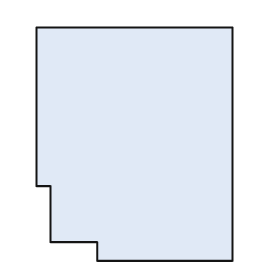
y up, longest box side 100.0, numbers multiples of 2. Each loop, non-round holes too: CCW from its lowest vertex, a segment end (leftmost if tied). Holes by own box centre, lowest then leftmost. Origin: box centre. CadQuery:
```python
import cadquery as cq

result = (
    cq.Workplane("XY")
    .moveTo(-16.0, -50.0)
    .lineTo(42.0, -50.0)
    .lineTo(42.0, 50.0)
    .lineTo(-42.0, 50.0)
    .lineTo(-42.0, -18.0)
    .lineTo(-36.0, -18.0)
    .lineTo(-36.0, -42.0)
    .lineTo(-16.0, -42.0)
    .close()
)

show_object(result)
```